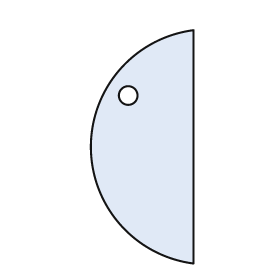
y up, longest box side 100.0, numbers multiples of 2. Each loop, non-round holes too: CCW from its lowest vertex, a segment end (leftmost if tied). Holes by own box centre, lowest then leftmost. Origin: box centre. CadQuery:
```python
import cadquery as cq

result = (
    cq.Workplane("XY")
    .moveTo(22.0, -50.0)
    .lineTo(22.0, 50.0)
    .threePointArc((-22.0, 0.0), (22.0, -50.0))
    .close()
    .moveTo(-6.0, 22.0)
    .circle(4.0)
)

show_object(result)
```